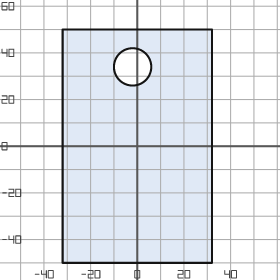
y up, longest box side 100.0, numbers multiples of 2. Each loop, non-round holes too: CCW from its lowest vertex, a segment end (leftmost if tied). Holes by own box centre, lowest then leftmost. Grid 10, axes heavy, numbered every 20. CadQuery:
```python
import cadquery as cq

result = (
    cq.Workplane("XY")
    .moveTo(-32.0, -50.0)
    .lineTo(32.0, -50.0)
    .lineTo(32.0, 50.0)
    .lineTo(-32.0, 50.0)
    .close()
    .moveTo(-2.0, 34.0)
    .circle(8.0)
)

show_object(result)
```